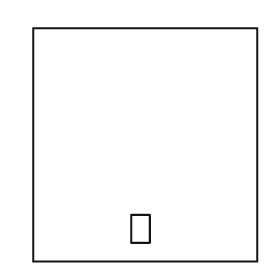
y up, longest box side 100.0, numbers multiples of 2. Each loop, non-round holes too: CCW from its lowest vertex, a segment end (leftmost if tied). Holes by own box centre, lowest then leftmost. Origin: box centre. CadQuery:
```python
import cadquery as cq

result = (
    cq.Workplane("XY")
    .moveTo(-48.0, -50.0)
    .lineTo(48.0, -50.0)
    .lineTo(48.0, 50.0)
    .lineTo(-48.0, 50.0)
    .close()
    .moveTo(-6.0, -42.0)
    .lineTo(2.0, -42.0)
    .lineTo(2.0, -30.0)
    .lineTo(-6.0, -30.0)
    .close()
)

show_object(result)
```